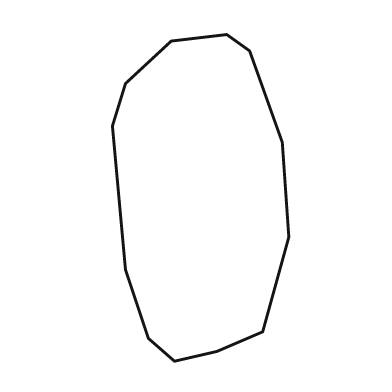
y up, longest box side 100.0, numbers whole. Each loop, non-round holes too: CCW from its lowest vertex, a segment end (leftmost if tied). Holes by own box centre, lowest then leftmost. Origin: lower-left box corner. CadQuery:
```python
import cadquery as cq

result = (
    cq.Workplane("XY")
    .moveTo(19.0, 0.0)
    .lineTo(32.0, 3.0)
    .lineTo(46.0, 9.0)
    .lineTo(54.0, 38.0)
    .lineTo(52.0, 67.0)
    .lineTo(42.0, 95.0)
    .lineTo(35.0, 100.0)
    .lineTo(18.0, 98.0)
    .lineTo(4.0, 85.0)
    .lineTo(0.0, 72.0)
    .lineTo(4.0, 28.0)
    .lineTo(11.0, 7.0)
    .close()
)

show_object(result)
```